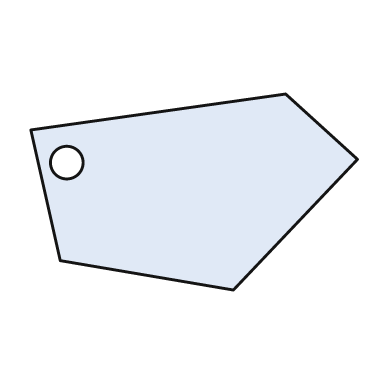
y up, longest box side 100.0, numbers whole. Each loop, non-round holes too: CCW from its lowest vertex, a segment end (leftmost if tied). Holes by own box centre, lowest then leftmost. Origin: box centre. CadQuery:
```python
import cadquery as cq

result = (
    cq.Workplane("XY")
    .moveTo(12.0, -30.0)
    .lineTo(50.0, 10.0)
    .lineTo(28.0, 30.0)
    .lineTo(-50.0, 19.0)
    .lineTo(-41.0, -21.0)
    .close()
    .moveTo(-39.0, 9.0)
    .circle(5.0)
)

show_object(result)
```